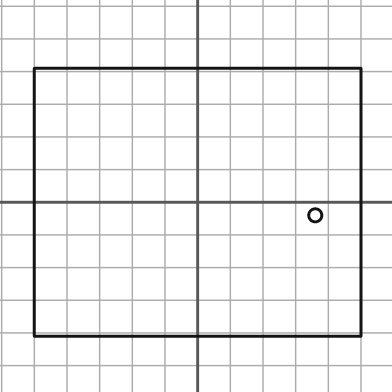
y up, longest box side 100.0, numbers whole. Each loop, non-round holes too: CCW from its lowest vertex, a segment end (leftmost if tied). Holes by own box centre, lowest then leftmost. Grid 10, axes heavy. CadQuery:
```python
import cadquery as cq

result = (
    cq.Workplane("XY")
    .moveTo(-50.0, -41.0)
    .lineTo(50.0, -41.0)
    .lineTo(50.0, 41.0)
    .lineTo(-50.0, 41.0)
    .close()
    .moveTo(36.0, -4.0)
    .circle(2.0)
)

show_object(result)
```